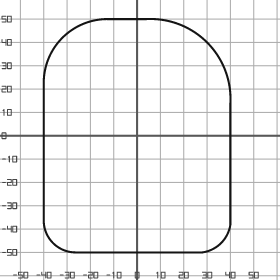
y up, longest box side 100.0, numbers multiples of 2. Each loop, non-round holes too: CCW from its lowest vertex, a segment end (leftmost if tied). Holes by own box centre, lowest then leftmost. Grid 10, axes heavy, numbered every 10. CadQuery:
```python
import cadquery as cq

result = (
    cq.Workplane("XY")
    .moveTo(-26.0, -50.0)
    .lineTo(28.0, -50.0)
    .threePointArc((36.0, -46.0), (40.0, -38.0))
    .lineTo(40.0, 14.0)
    .threePointArc((30.0, 40.0), (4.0, 50.0))
    .lineTo(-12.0, 50.0)
    .threePointArc((-32.0, 42.0), (-40.0, 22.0))
    .lineTo(-40.0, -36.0)
    .threePointArc((-36.0, -46.0), (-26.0, -50.0))
    .close()
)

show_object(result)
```